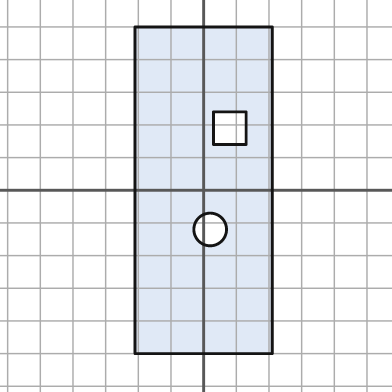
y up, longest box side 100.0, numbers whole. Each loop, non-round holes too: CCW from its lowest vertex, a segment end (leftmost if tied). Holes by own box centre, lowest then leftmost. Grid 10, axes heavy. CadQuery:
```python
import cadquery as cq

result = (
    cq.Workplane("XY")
    .moveTo(-21.0, -50.0)
    .lineTo(21.0, -50.0)
    .lineTo(21.0, 50.0)
    .lineTo(-21.0, 50.0)
    .close()
    .moveTo(2.0, -12.0)
    .circle(5.0)
    .moveTo(3.0, 14.0)
    .lineTo(13.0, 14.0)
    .lineTo(13.0, 24.0)
    .lineTo(3.0, 24.0)
    .close()
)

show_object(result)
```